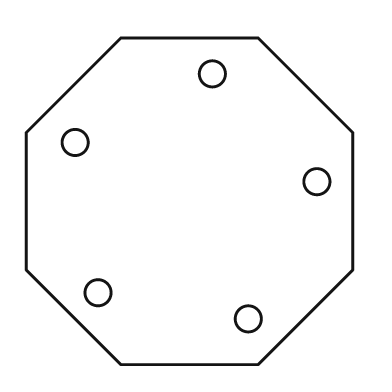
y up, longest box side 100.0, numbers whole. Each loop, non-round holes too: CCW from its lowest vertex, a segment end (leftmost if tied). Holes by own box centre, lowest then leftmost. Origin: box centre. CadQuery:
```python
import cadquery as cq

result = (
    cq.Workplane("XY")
    .moveTo(-21.0, -50.0)
    .lineTo(21.0, -50.0)
    .lineTo(50.0, -21.0)
    .lineTo(50.0, 21.0)
    .lineTo(21.0, 50.0)
    .lineTo(-21.0, 50.0)
    .lineTo(-50.0, 21.0)
    .lineTo(-50.0, -21.0)
    .close()
    .moveTo(18.0, -36.0)
    .circle(4.0)
    .moveTo(-28.0, -28.0)
    .circle(4.0)
    .moveTo(39.0, 6.0)
    .circle(4.0)
    .moveTo(-35.0, 18.0)
    .circle(4.0)
    .moveTo(7.0, 39.0)
    .circle(4.0)
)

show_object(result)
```